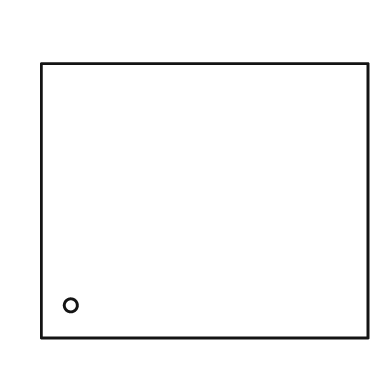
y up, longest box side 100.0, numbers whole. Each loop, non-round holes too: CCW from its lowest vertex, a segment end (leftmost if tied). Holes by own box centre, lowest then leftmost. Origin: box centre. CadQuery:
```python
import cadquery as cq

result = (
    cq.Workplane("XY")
    .moveTo(-50.0, -42.0)
    .lineTo(50.0, -42.0)
    .lineTo(50.0, 42.0)
    .lineTo(-50.0, 42.0)
    .close()
    .moveTo(-41.0, -32.0)
    .circle(2.0)
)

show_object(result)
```